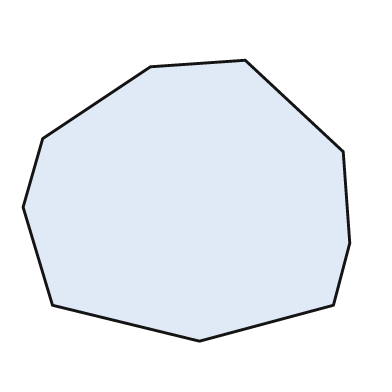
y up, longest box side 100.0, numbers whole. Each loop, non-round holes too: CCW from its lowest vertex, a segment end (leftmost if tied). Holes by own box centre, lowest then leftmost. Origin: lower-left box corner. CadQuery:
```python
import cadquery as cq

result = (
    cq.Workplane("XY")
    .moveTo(54.0, 0.0)
    .lineTo(95.0, 11.0)
    .lineTo(100.0, 30.0)
    .lineTo(98.0, 58.0)
    .lineTo(68.0, 86.0)
    .lineTo(39.0, 84.0)
    .lineTo(6.0, 62.0)
    .lineTo(0.0, 41.0)
    .lineTo(9.0, 11.0)
    .close()
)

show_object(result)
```